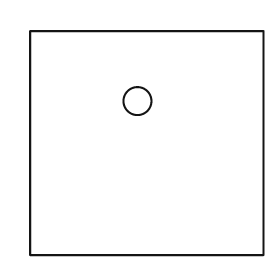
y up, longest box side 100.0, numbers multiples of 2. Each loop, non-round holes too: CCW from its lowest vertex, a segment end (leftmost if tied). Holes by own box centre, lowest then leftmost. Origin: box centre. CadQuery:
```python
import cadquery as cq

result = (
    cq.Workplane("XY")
    .moveTo(-50.0, -48.0)
    .lineTo(50.0, -48.0)
    .lineTo(50.0, 48.0)
    .lineTo(-50.0, 48.0)
    .close()
    .moveTo(-4.0, 18.0)
    .circle(6.0)
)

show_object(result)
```